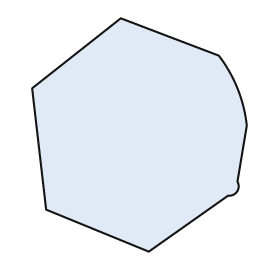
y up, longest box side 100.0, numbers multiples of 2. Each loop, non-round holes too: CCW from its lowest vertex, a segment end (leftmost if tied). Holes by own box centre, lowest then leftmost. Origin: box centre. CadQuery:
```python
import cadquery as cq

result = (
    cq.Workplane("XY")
    .moveTo(4.0, -50.0)
    .lineTo(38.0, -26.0)
    .threePointArc((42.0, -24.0), (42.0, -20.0))
    .lineTo(46.0, 4.0)
    .threePointArc((42.0, 20.0), (34.0, 34.0))
    .lineTo(-8.0, 50.0)
    .lineTo(-46.0, 20.0)
    .lineTo(-40.0, -32.0)
    .close()
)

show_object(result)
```